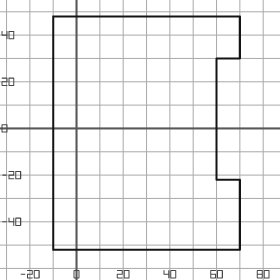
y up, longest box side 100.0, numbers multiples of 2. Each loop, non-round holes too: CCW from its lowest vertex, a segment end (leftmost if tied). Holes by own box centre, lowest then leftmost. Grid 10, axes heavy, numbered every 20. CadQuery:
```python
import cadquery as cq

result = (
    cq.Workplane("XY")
    .moveTo(-10.0, -52.0)
    .lineTo(70.0, -52.0)
    .lineTo(70.0, -22.0)
    .lineTo(60.0, -22.0)
    .lineTo(60.0, 30.0)
    .lineTo(70.0, 30.0)
    .lineTo(70.0, 48.0)
    .lineTo(-10.0, 48.0)
    .close()
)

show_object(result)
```